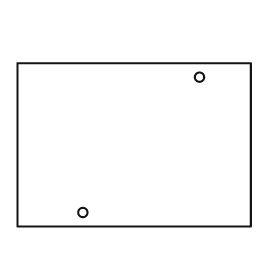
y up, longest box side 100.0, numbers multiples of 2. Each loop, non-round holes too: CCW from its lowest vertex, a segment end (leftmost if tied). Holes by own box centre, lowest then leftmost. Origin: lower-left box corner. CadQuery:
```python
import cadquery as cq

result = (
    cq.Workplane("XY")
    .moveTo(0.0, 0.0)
    .lineTo(100.0, 0.0)
    .lineTo(100.0, 70.0)
    .lineTo(0.0, 70.0)
    .close()
    .moveTo(28.0, 6.0)
    .circle(2.0)
    .moveTo(78.0, 64.0)
    .circle(2.0)
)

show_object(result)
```